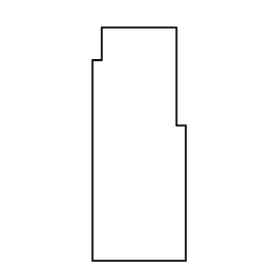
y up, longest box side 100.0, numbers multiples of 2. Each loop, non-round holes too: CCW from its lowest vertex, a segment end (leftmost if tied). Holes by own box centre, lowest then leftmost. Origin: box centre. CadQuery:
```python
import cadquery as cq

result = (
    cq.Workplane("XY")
    .moveTo(-20.0, -50.0)
    .lineTo(20.0, -50.0)
    .lineTo(20.0, 8.0)
    .lineTo(16.0, 8.0)
    .lineTo(16.0, 50.0)
    .lineTo(-16.0, 50.0)
    .lineTo(-16.0, 36.0)
    .lineTo(-20.0, 36.0)
    .close()
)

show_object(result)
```